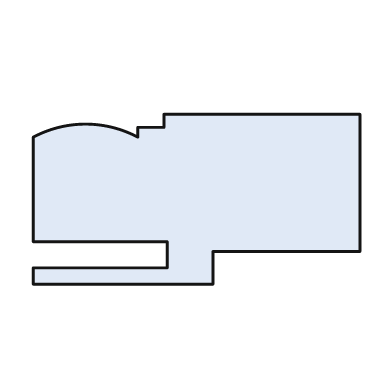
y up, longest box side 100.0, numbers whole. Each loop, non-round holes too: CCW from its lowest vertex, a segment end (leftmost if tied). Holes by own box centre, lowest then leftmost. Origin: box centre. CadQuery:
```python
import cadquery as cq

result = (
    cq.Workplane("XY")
    .moveTo(-50.0, -26.0)
    .lineTo(5.0, -26.0)
    .lineTo(5.0, -16.0)
    .lineTo(50.0, -16.0)
    .lineTo(50.0, 26.0)
    .lineTo(-10.0, 26.0)
    .lineTo(-10.0, 22.0)
    .lineTo(-18.0, 22.0)
    .lineTo(-18.0, 19.0)
    .threePointArc((-34.0, 23.0), (-50.0, 19.0))
    .lineTo(-50.0, -13.0)
    .lineTo(-9.0, -13.0)
    .lineTo(-9.0, -21.0)
    .lineTo(-50.0, -21.0)
    .close()
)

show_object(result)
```